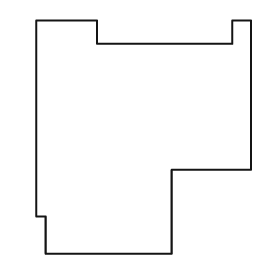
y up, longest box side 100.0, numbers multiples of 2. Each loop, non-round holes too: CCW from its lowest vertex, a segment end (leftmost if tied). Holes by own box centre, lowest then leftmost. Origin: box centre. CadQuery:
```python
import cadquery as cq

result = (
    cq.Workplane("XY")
    .moveTo(-42.0, -50.0)
    .lineTo(12.0, -50.0)
    .lineTo(12.0, -14.0)
    .lineTo(46.0, -14.0)
    .lineTo(46.0, 50.0)
    .lineTo(38.0, 50.0)
    .lineTo(38.0, 40.0)
    .lineTo(-20.0, 40.0)
    .lineTo(-20.0, 50.0)
    .lineTo(-46.0, 50.0)
    .lineTo(-46.0, -34.0)
    .lineTo(-42.0, -34.0)
    .close()
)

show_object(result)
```